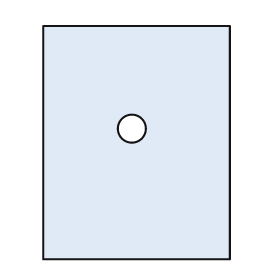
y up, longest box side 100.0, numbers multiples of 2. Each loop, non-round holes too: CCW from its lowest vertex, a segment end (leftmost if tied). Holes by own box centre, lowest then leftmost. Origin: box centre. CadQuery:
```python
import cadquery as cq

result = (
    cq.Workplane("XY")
    .moveTo(-40.0, -50.0)
    .lineTo(40.0, -50.0)
    .lineTo(40.0, 50.0)
    .lineTo(-40.0, 50.0)
    .close()
    .moveTo(-2.0, 6.0)
    .circle(6.0)
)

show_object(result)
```